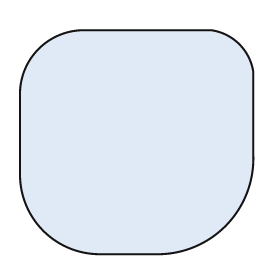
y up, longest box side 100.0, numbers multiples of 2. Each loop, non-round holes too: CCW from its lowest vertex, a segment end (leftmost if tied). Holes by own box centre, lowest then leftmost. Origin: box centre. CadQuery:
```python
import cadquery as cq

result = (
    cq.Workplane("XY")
    .moveTo(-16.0, -48.0)
    .lineTo(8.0, -48.0)
    .threePointArc((38.0, -36.0), (50.0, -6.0))
    .lineTo(50.0, 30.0)
    .threePointArc((44.0, 42.0), (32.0, 48.0))
    .lineTo(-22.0, 48.0)
    .threePointArc((-42.0, 40.0), (-50.0, 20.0))
    .lineTo(-50.0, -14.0)
    .threePointArc((-40.0, -38.0), (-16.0, -48.0))
    .close()
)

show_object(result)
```